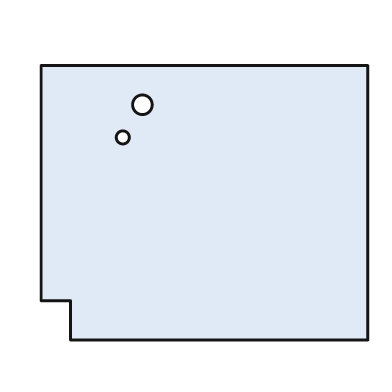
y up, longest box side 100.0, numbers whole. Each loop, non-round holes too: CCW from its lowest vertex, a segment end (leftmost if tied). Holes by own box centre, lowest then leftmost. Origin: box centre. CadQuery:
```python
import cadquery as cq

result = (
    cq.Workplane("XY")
    .moveTo(-41.0, -42.0)
    .lineTo(50.0, -42.0)
    .lineTo(50.0, 42.0)
    .lineTo(-50.0, 42.0)
    .lineTo(-50.0, -30.0)
    .lineTo(-41.0, -30.0)
    .close()
    .moveTo(-25.0, 20.0)
    .circle(2.0)
    .moveTo(-19.0, 30.0)
    .circle(3.0)
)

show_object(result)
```